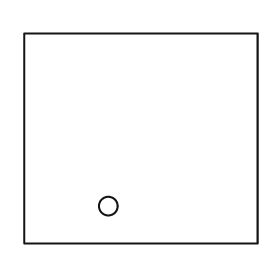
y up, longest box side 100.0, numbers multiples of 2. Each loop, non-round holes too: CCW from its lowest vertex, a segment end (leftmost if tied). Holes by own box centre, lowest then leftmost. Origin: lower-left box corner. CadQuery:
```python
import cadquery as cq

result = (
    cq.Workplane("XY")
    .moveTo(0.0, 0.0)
    .lineTo(100.0, 0.0)
    .lineTo(100.0, 90.0)
    .lineTo(0.0, 90.0)
    .close()
    .moveTo(36.0, 16.0)
    .circle(4.0)
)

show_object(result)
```